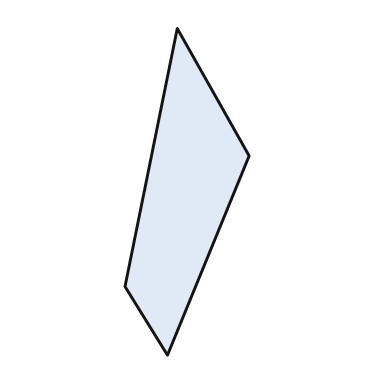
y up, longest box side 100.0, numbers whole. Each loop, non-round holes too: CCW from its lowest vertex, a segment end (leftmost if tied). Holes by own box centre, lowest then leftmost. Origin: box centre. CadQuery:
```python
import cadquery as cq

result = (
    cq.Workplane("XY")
    .moveTo(-6.0, -50.0)
    .lineTo(19.0, 11.0)
    .lineTo(-3.0, 50.0)
    .lineTo(-19.0, -29.0)
    .close()
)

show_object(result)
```